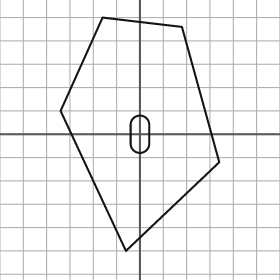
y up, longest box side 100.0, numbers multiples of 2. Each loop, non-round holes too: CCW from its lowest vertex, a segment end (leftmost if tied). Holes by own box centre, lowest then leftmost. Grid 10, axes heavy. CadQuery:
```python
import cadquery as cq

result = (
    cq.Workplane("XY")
    .moveTo(-6.0, -50.0)
    .lineTo(34.0, -12.0)
    .lineTo(18.0, 46.0)
    .lineTo(-16.0, 50.0)
    .lineTo(-34.0, 10.0)
    .close()
    .moveTo(-4.0, -4.0)
    .threePointArc((0.0, -8.0), (4.0, -4.0))
    .lineTo(4.0, 4.0)
    .threePointArc((0.0, 8.0), (-4.0, 4.0))
    .close()
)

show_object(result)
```